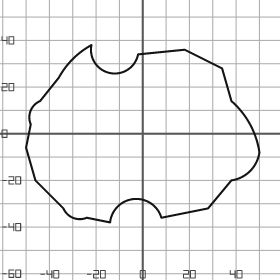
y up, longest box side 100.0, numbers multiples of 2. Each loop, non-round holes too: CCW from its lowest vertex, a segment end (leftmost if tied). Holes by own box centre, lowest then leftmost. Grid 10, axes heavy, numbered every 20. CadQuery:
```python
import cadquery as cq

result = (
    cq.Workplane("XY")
    .moveTo(-14.0, -38.0)
    .threePointArc((-4.0, -28.0), (8.0, -36.0))
    .lineTo(28.0, -32.0)
    .lineTo(38.0, -20.0)
    .threePointArc((46.0, -16.0), (50.0, -8.0))
    .threePointArc((46.0, 4.0), (38.0, 14.0))
    .lineTo(34.0, 28.0)
    .lineTo(18.0, 36.0)
    .lineTo(-2.0, 34.0)
    .threePointArc((-14.0, 26.0), (-22.0, 38.0))
    .threePointArc((-30.0, 32.0), (-36.0, 24.0))
    .lineTo(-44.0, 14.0)
    .threePointArc((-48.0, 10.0), (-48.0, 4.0))
    .lineTo(-50.0, -6.0)
    .lineTo(-46.0, -20.0)
    .lineTo(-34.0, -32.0)
    .threePointArc((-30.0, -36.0), (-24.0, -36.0))
    .close()
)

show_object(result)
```